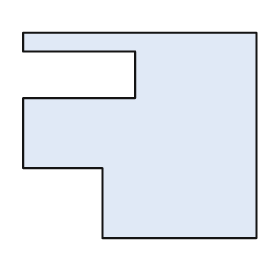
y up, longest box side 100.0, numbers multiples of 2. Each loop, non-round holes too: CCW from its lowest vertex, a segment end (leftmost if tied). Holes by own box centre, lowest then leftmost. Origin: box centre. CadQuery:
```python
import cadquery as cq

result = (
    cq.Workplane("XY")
    .moveTo(-16.0, -44.0)
    .lineTo(50.0, -44.0)
    .lineTo(50.0, 44.0)
    .lineTo(-50.0, 44.0)
    .lineTo(-50.0, 36.0)
    .lineTo(-2.0, 36.0)
    .lineTo(-2.0, 16.0)
    .lineTo(-50.0, 16.0)
    .lineTo(-50.0, -14.0)
    .lineTo(-16.0, -14.0)
    .close()
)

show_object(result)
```